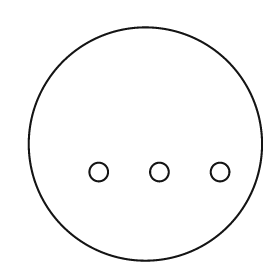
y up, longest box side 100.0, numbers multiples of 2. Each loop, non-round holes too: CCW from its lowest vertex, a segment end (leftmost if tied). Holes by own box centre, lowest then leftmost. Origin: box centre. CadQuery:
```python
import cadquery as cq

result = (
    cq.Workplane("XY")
    .moveTo(0.0, 0.0)
    .circle(50.0)
    .moveTo(-20.0, -12.0)
    .circle(4.0)
    .moveTo(6.0, -12.0)
    .circle(4.0)
    .moveTo(32.0, -12.0)
    .circle(4.0)
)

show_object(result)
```